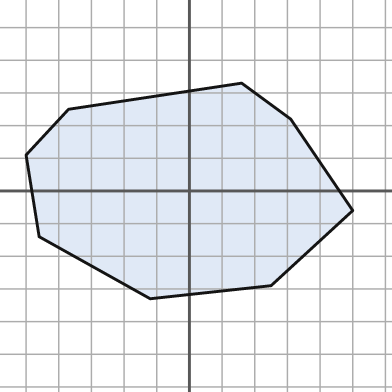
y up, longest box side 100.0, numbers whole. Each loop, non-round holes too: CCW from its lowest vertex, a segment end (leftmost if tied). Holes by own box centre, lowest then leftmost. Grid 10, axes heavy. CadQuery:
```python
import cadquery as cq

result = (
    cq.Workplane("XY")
    .moveTo(-12.0, -33.0)
    .lineTo(25.0, -29.0)
    .lineTo(50.0, -6.0)
    .lineTo(31.0, 22.0)
    .lineTo(16.0, 33.0)
    .lineTo(-37.0, 25.0)
    .lineTo(-50.0, 11.0)
    .lineTo(-46.0, -14.0)
    .close()
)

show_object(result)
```